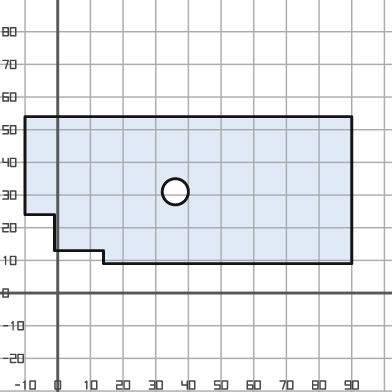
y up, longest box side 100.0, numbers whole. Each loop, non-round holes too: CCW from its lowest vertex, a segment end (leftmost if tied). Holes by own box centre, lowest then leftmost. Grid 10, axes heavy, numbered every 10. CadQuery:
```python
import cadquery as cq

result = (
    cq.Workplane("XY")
    .moveTo(14.0, 9.0)
    .lineTo(90.0, 9.0)
    .lineTo(90.0, 54.0)
    .lineTo(-10.0, 54.0)
    .lineTo(-10.0, 24.0)
    .lineTo(-1.0, 24.0)
    .lineTo(-1.0, 13.0)
    .lineTo(14.0, 13.0)
    .close()
    .moveTo(36.0, 31.0)
    .circle(4.0)
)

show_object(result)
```